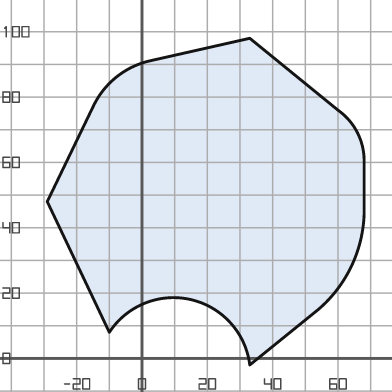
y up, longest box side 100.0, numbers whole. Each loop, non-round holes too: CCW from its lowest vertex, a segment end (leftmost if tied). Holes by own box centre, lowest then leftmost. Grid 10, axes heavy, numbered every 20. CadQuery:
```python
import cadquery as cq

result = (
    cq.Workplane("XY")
    .moveTo(33.0, -2.0)
    .lineTo(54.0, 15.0)
    .threePointArc((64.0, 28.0), (68.0, 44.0))
    .lineTo(68.0, 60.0)
    .threePointArc((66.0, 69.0), (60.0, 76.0))
    .lineTo(33.0, 98.0)
    .lineTo(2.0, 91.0)
    .threePointArc((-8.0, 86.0), (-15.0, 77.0))
    .lineTo(-29.0, 48.0)
    .lineTo(-10.0, 8.0)
    .threePointArc((15.0, 18.0), (33.0, -2.0))
    .close()
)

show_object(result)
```